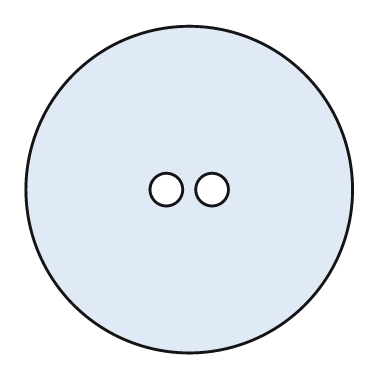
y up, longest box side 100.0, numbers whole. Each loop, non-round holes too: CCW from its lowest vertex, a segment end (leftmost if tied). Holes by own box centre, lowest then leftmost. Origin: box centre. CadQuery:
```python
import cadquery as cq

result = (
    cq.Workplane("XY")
    .moveTo(0.0, 0.0)
    .circle(50.0)
    .moveTo(-7.0, 0.0)
    .circle(5.0)
    .moveTo(7.0, 0.0)
    .circle(5.0)
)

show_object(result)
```